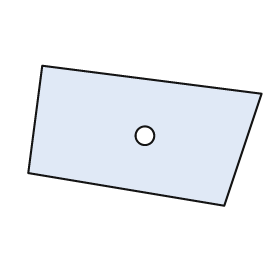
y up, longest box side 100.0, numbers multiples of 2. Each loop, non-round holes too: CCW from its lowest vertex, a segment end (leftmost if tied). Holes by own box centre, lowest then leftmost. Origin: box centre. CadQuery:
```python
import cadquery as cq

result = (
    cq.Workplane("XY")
    .moveTo(34.0, -30.0)
    .lineTo(50.0, 18.0)
    .lineTo(-44.0, 30.0)
    .lineTo(-50.0, -16.0)
    .close()
    .moveTo(0.0, 0.0)
    .circle(4.0)
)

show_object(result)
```